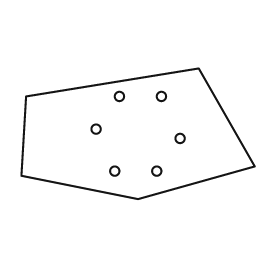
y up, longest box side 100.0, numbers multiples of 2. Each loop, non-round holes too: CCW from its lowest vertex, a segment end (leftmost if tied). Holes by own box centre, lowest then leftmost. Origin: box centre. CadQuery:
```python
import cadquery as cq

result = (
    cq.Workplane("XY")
    .moveTo(0.0, -28.0)
    .lineTo(50.0, -14.0)
    .lineTo(26.0, 28.0)
    .lineTo(-48.0, 16.0)
    .lineTo(-50.0, -18.0)
    .close()
    .moveTo(-10.0, -16.0)
    .circle(2.0)
    .moveTo(8.0, -16.0)
    .circle(2.0)
    .moveTo(18.0, -2.0)
    .circle(2.0)
    .moveTo(-18.0, 2.0)
    .circle(2.0)
    .moveTo(-8.0, 16.0)
    .circle(2.0)
    .moveTo(10.0, 16.0)
    .circle(2.0)
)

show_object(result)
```